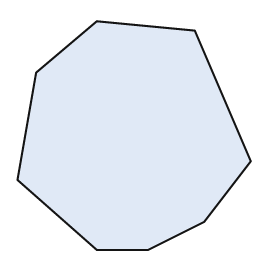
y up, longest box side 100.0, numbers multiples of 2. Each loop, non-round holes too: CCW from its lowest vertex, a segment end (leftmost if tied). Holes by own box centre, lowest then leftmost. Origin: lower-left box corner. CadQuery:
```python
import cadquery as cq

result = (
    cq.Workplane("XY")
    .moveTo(34.0, 0.0)
    .lineTo(56.0, 0.0)
    .lineTo(80.0, 12.0)
    .lineTo(100.0, 38.0)
    .lineTo(76.0, 94.0)
    .lineTo(34.0, 98.0)
    .lineTo(8.0, 76.0)
    .lineTo(0.0, 30.0)
    .close()
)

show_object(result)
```